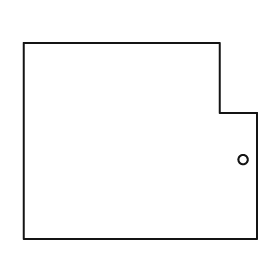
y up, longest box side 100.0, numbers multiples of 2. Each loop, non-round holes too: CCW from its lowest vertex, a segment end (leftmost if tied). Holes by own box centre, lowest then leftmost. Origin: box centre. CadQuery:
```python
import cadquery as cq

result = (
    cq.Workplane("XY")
    .moveTo(-50.0, -42.0)
    .lineTo(50.0, -42.0)
    .lineTo(50.0, 12.0)
    .lineTo(34.0, 12.0)
    .lineTo(34.0, 42.0)
    .lineTo(-50.0, 42.0)
    .close()
    .moveTo(44.0, -8.0)
    .circle(2.0)
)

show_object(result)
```